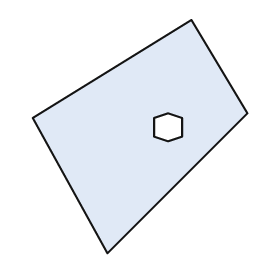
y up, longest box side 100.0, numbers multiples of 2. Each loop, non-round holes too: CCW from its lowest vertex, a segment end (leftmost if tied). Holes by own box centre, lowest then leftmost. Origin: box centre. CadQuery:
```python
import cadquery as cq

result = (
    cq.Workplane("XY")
    .moveTo(-14.0, -50.0)
    .lineTo(46.0, 10.0)
    .lineTo(22.0, 50.0)
    .lineTo(-46.0, 8.0)
    .close()
    .moveTo(12.0, -2.0)
    .lineTo(18.0, 0.0)
    .lineTo(18.0, 8.0)
    .lineTo(12.0, 10.0)
    .lineTo(6.0, 8.0)
    .lineTo(6.0, 0.0)
    .close()
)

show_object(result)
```